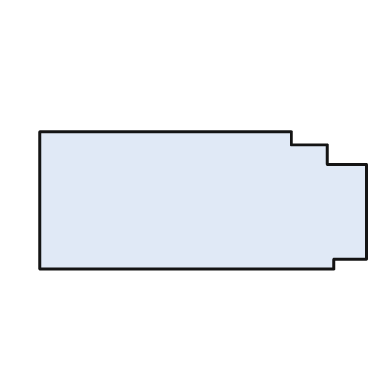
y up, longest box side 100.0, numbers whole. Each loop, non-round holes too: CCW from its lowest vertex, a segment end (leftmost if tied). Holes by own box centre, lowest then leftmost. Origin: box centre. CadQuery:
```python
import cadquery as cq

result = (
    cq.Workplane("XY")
    .moveTo(-50.0, -21.0)
    .lineTo(40.0, -21.0)
    .lineTo(40.0, -18.0)
    .lineTo(50.0, -18.0)
    .lineTo(50.0, 11.0)
    .lineTo(38.0, 11.0)
    .lineTo(38.0, 17.0)
    .lineTo(27.0, 17.0)
    .lineTo(27.0, 21.0)
    .lineTo(-50.0, 21.0)
    .close()
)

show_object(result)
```